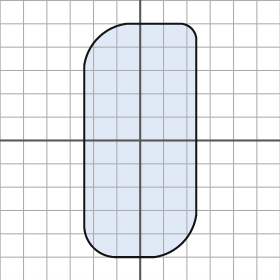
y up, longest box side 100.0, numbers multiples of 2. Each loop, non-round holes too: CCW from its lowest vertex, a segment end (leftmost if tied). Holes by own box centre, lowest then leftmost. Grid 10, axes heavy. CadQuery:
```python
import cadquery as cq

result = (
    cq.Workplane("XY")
    .moveTo(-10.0, -50.0)
    .lineTo(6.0, -50.0)
    .threePointArc((18.0, -44.0), (24.0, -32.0))
    .lineTo(24.0, 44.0)
    .threePointArc((22.0, 48.0), (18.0, 50.0))
    .lineTo(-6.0, 50.0)
    .threePointArc((-18.0, 44.0), (-24.0, 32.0))
    .lineTo(-24.0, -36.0)
    .threePointArc((-20.0, -46.0), (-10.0, -50.0))
    .close()
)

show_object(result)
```